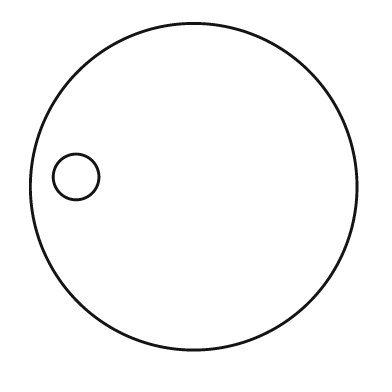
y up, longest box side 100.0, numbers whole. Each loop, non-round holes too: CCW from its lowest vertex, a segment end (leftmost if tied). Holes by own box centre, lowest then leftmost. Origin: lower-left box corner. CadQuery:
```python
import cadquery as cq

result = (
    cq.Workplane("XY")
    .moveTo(50.0, 50.0)
    .circle(50.0)
    .moveTo(14.0, 53.0)
    .circle(7.0)
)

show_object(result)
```